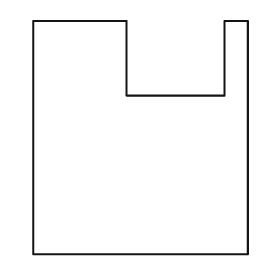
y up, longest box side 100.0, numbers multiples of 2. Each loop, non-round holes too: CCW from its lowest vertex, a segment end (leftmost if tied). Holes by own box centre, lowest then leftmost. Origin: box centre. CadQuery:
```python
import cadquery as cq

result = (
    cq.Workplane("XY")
    .moveTo(-46.0, -50.0)
    .lineTo(46.0, -50.0)
    .lineTo(46.0, 50.0)
    .lineTo(36.0, 50.0)
    .lineTo(36.0, 18.0)
    .lineTo(-6.0, 18.0)
    .lineTo(-6.0, 50.0)
    .lineTo(-46.0, 50.0)
    .close()
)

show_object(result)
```